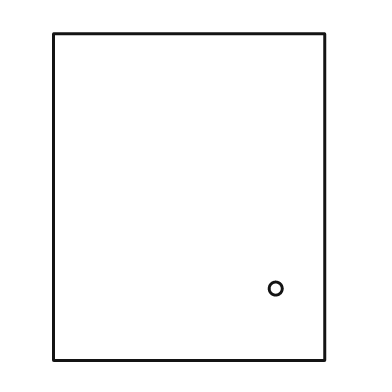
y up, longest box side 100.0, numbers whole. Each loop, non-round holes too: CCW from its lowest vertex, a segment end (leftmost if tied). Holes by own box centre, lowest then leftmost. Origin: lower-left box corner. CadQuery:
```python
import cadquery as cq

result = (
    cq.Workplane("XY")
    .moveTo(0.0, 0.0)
    .lineTo(83.0, 0.0)
    .lineTo(83.0, 100.0)
    .lineTo(0.0, 100.0)
    .close()
    .moveTo(68.0, 22.0)
    .circle(2.0)
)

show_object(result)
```